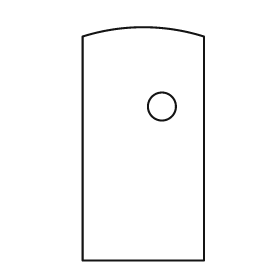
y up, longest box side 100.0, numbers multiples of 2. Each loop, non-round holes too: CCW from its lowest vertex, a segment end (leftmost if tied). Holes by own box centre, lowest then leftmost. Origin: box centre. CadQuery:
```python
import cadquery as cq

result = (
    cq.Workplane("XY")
    .moveTo(-26.0, -50.0)
    .lineTo(26.0, -50.0)
    .lineTo(26.0, 46.0)
    .threePointArc((0.0, 50.0), (-26.0, 46.0))
    .close()
    .moveTo(8.0, 16.0)
    .circle(6.0)
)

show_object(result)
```